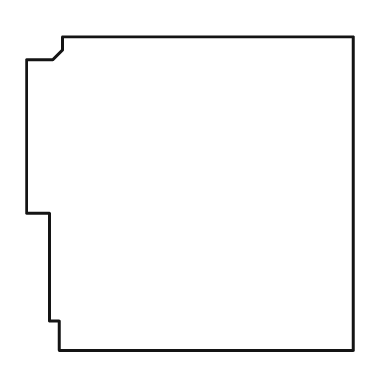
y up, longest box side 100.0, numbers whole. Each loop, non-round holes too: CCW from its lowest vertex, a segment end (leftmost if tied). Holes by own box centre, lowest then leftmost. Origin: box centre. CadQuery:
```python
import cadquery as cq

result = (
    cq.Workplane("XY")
    .moveTo(-40.0, -48.0)
    .lineTo(50.0, -48.0)
    .lineTo(50.0, 48.0)
    .lineTo(-39.0, 48.0)
    .lineTo(-39.0, 44.0)
    .lineTo(-42.0, 41.0)
    .lineTo(-50.0, 41.0)
    .lineTo(-50.0, -6.0)
    .lineTo(-43.0, -6.0)
    .lineTo(-43.0, -39.0)
    .lineTo(-40.0, -39.0)
    .close()
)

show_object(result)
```